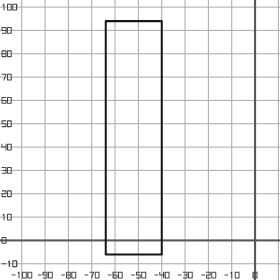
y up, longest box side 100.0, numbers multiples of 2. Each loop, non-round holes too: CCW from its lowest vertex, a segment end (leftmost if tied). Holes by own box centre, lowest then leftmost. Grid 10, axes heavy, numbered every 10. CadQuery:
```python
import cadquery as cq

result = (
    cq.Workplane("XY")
    .moveTo(-64.0, -6.0)
    .lineTo(-40.0, -6.0)
    .lineTo(-40.0, 94.0)
    .lineTo(-64.0, 94.0)
    .close()
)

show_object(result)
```